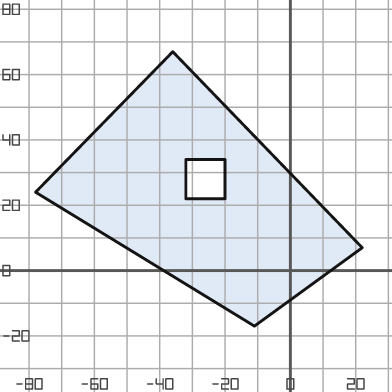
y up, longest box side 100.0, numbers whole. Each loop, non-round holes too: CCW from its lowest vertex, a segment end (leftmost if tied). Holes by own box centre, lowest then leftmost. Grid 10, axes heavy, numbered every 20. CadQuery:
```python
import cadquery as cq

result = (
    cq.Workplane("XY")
    .moveTo(-11.0, -17.0)
    .lineTo(22.0, 7.0)
    .lineTo(-36.0, 67.0)
    .lineTo(-78.0, 24.0)
    .close()
    .moveTo(-32.0, 22.0)
    .lineTo(-20.0, 22.0)
    .lineTo(-20.0, 34.0)
    .lineTo(-32.0, 34.0)
    .close()
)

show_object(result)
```